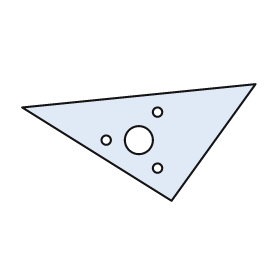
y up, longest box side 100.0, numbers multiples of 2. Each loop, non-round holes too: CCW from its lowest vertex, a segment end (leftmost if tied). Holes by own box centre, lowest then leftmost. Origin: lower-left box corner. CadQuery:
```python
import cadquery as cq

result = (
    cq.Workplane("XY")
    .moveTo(64.0, 0.0)
    .lineTo(100.0, 50.0)
    .lineTo(0.0, 40.0)
    .close()
    .moveTo(58.0, 14.0)
    .circle(2.0)
    .moveTo(36.0, 26.0)
    .circle(2.0)
    .moveTo(50.0, 26.0)
    .circle(6.0)
    .moveTo(58.0, 38.0)
    .circle(2.0)
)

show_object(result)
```